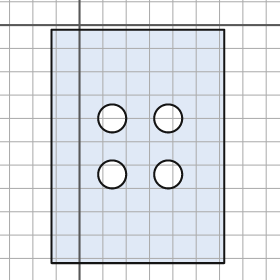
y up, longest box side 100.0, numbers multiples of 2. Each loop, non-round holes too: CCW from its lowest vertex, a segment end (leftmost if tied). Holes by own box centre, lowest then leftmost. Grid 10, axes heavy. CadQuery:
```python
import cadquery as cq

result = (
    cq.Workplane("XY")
    .moveTo(-12.0, -102.0)
    .lineTo(62.0, -102.0)
    .lineTo(62.0, -2.0)
    .lineTo(-12.0, -2.0)
    .close()
    .moveTo(14.0, -64.0)
    .circle(6.0)
    .moveTo(38.0, -64.0)
    .circle(6.0)
    .moveTo(14.0, -40.0)
    .circle(6.0)
    .moveTo(38.0, -40.0)
    .circle(6.0)
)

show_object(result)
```